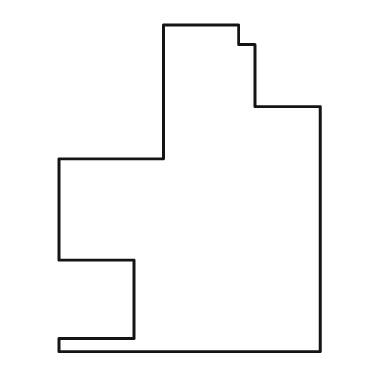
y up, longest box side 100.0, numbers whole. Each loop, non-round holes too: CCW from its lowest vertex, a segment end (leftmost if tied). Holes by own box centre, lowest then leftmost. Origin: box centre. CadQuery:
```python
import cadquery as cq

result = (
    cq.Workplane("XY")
    .moveTo(-40.0, -50.0)
    .lineTo(40.0, -50.0)
    .lineTo(40.0, 25.0)
    .lineTo(20.0, 25.0)
    .lineTo(20.0, 44.0)
    .lineTo(15.0, 44.0)
    .lineTo(15.0, 50.0)
    .lineTo(-8.0, 50.0)
    .lineTo(-8.0, 9.0)
    .lineTo(-40.0, 9.0)
    .lineTo(-40.0, -22.0)
    .lineTo(-17.0, -22.0)
    .lineTo(-17.0, -46.0)
    .lineTo(-40.0, -46.0)
    .close()
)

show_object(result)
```